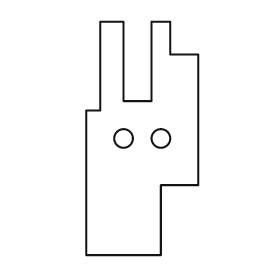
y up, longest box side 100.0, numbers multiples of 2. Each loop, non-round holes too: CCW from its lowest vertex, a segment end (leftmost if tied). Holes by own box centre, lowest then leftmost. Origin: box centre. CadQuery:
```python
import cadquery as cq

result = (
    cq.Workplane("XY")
    .moveTo(-24.0, -50.0)
    .lineTo(8.0, -50.0)
    .lineTo(8.0, -20.0)
    .lineTo(24.0, -20.0)
    .lineTo(24.0, 36.0)
    .lineTo(12.0, 36.0)
    .lineTo(12.0, 50.0)
    .lineTo(4.0, 50.0)
    .lineTo(4.0, 16.0)
    .lineTo(-8.0, 16.0)
    .lineTo(-8.0, 50.0)
    .lineTo(-18.0, 50.0)
    .lineTo(-18.0, 12.0)
    .lineTo(-24.0, 12.0)
    .close()
    .moveTo(-8.0, 0.0)
    .circle(4.0)
    .moveTo(8.0, 0.0)
    .circle(4.0)
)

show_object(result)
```